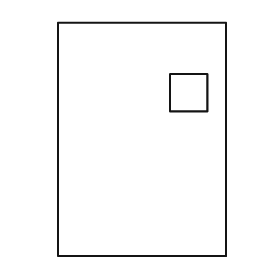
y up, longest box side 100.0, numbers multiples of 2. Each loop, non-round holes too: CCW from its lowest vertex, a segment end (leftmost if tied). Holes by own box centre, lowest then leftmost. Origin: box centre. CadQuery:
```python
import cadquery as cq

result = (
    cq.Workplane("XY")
    .moveTo(-36.0, -50.0)
    .lineTo(36.0, -50.0)
    .lineTo(36.0, 50.0)
    .lineTo(-36.0, 50.0)
    .close()
    .moveTo(12.0, 12.0)
    .lineTo(28.0, 12.0)
    .lineTo(28.0, 28.0)
    .lineTo(12.0, 28.0)
    .close()
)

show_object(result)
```